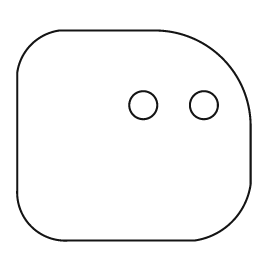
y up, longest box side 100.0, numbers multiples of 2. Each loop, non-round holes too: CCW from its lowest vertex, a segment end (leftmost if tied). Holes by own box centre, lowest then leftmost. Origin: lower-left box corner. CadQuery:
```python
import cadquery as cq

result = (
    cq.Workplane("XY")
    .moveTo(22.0, 0.0)
    .lineTo(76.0, 0.0)
    .threePointArc((92.0, 8.0), (100.0, 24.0))
    .lineTo(100.0, 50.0)
    .threePointArc((88.0, 78.0), (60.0, 90.0))
    .lineTo(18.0, 90.0)
    .threePointArc((6.0, 84.0), (0.0, 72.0))
    .lineTo(0.0, 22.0)
    .threePointArc((6.0, 6.0), (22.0, 0.0))
    .close()
    .moveTo(54.0, 58.0)
    .circle(6.0)
    .moveTo(80.0, 58.0)
    .circle(6.0)
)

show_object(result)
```